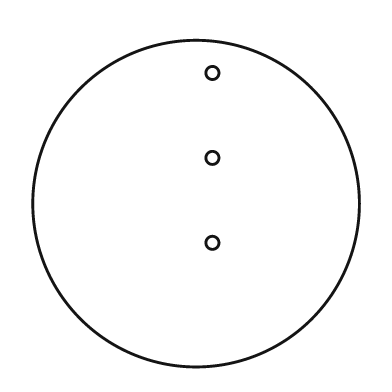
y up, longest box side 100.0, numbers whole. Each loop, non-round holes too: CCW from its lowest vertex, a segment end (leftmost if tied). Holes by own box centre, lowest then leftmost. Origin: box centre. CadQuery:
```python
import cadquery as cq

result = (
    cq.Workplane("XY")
    .moveTo(0.0, 0.0)
    .circle(50.0)
    .moveTo(5.0, -12.0)
    .circle(2.0)
    .moveTo(5.0, 14.0)
    .circle(2.0)
    .moveTo(5.0, 40.0)
    .circle(2.0)
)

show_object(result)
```